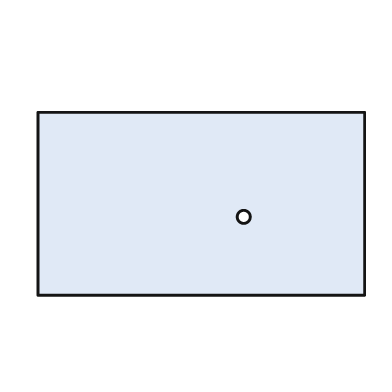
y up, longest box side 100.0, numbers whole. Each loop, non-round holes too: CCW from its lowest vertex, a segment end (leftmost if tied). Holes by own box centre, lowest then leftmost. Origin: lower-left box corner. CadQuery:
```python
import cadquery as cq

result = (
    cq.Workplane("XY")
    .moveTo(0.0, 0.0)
    .lineTo(100.0, 0.0)
    .lineTo(100.0, 56.0)
    .lineTo(0.0, 56.0)
    .close()
    .moveTo(63.0, 24.0)
    .circle(2.0)
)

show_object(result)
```